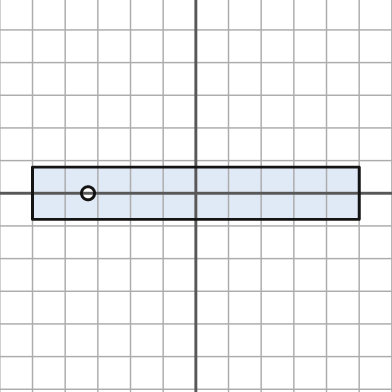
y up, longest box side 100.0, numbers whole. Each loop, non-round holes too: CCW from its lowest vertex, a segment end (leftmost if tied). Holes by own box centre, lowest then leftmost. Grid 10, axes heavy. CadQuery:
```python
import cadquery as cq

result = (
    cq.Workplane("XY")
    .moveTo(-50.0, -8.0)
    .lineTo(50.0, -8.0)
    .lineTo(50.0, 8.0)
    .lineTo(-50.0, 8.0)
    .close()
    .moveTo(-33.0, 0.0)
    .circle(2.0)
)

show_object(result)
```